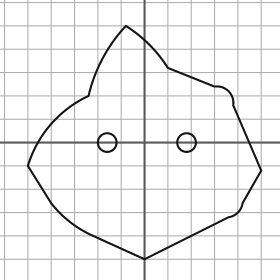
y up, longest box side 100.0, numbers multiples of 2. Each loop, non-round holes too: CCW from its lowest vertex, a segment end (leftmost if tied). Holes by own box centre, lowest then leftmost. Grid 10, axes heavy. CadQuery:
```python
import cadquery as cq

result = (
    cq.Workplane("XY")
    .moveTo(0.0, -50.0)
    .lineTo(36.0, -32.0)
    .threePointArc((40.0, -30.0), (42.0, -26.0))
    .lineTo(50.0, -12.0)
    .lineTo(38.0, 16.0)
    .threePointArc((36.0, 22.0), (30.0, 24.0))
    .lineTo(10.0, 32.0)
    .threePointArc((2.0, 42.0), (-8.0, 50.0))
    .threePointArc((-18.0, 36.0), (-24.0, 20.0))
    .threePointArc((-40.0, 8.0), (-50.0, -10.0))
    .lineTo(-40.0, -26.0)
    .threePointArc((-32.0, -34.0), (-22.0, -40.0))
    .close()
    .moveTo(-16.0, 0.0)
    .circle(4.0)
    .moveTo(18.0, 0.0)
    .circle(4.0)
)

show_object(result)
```